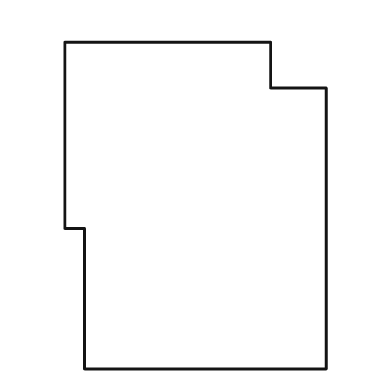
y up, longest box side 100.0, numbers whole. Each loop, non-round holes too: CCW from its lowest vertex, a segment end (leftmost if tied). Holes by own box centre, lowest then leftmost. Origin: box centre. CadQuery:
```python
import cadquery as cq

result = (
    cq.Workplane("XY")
    .moveTo(-34.0, -50.0)
    .lineTo(40.0, -50.0)
    .lineTo(40.0, 36.0)
    .lineTo(23.0, 36.0)
    .lineTo(23.0, 50.0)
    .lineTo(-40.0, 50.0)
    .lineTo(-40.0, -7.0)
    .lineTo(-34.0, -7.0)
    .close()
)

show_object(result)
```